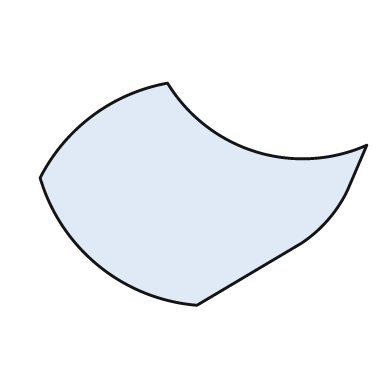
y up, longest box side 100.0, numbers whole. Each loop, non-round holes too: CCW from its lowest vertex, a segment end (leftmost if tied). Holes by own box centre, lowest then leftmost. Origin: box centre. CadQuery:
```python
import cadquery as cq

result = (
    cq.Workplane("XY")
    .moveTo(-2.0, -34.0)
    .lineTo(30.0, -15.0)
    .threePointArc((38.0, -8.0), (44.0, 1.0))
    .lineTo(50.0, 15.0)
    .threePointArc((16.0, 13.0), (-11.0, 34.0))
    .threePointArc((-34.0, 24.0), (-50.0, 5.0))
    .threePointArc((-32.0, -22.0), (-2.0, -34.0))
    .close()
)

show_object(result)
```